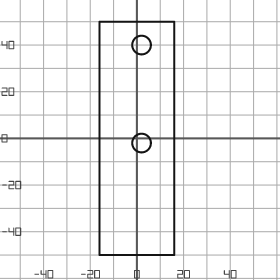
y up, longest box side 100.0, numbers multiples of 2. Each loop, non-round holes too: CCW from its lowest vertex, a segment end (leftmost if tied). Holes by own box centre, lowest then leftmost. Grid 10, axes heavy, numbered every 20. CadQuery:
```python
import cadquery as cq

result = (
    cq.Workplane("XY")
    .moveTo(-16.0, -50.0)
    .lineTo(16.0, -50.0)
    .lineTo(16.0, 50.0)
    .lineTo(-16.0, 50.0)
    .close()
    .moveTo(2.0, -2.0)
    .circle(4.0)
    .moveTo(2.0, 40.0)
    .circle(4.0)
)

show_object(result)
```